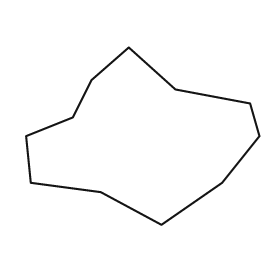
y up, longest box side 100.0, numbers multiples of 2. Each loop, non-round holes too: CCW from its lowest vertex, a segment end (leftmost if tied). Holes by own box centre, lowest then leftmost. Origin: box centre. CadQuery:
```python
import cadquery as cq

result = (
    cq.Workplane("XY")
    .moveTo(8.0, -38.0)
    .lineTo(34.0, -20.0)
    .lineTo(50.0, 0.0)
    .lineTo(46.0, 14.0)
    .lineTo(14.0, 20.0)
    .lineTo(-6.0, 38.0)
    .lineTo(-22.0, 24.0)
    .lineTo(-30.0, 8.0)
    .lineTo(-50.0, 0.0)
    .lineTo(-48.0, -20.0)
    .lineTo(-18.0, -24.0)
    .close()
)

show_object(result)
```